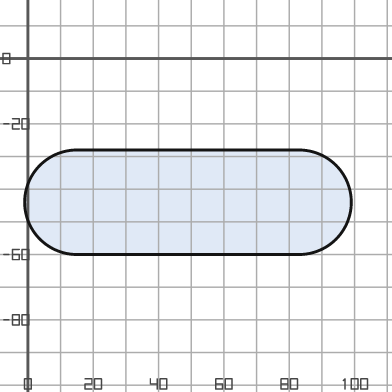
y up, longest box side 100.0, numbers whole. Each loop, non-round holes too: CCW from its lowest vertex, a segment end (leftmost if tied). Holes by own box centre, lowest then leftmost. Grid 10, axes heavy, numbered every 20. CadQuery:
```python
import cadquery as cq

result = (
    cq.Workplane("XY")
    .moveTo(15.0, -60.0)
    .lineTo(83.0, -60.0)
    .threePointArc((99.0, -44.0), (83.0, -28.0))
    .lineTo(15.0, -28.0)
    .threePointArc((-1.0, -44.0), (15.0, -60.0))
    .close()
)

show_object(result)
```